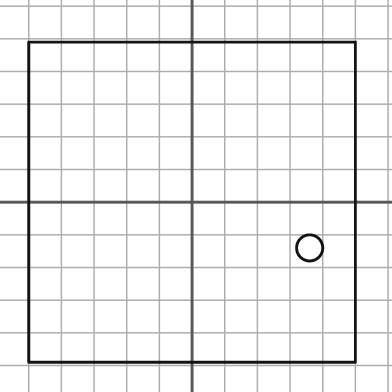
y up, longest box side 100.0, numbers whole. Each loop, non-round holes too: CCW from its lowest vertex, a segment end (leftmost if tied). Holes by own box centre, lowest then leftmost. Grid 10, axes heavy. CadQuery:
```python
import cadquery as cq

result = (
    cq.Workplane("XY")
    .moveTo(-50.0, -49.0)
    .lineTo(50.0, -49.0)
    .lineTo(50.0, 49.0)
    .lineTo(-50.0, 49.0)
    .close()
    .moveTo(36.0, -14.0)
    .circle(4.0)
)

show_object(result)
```